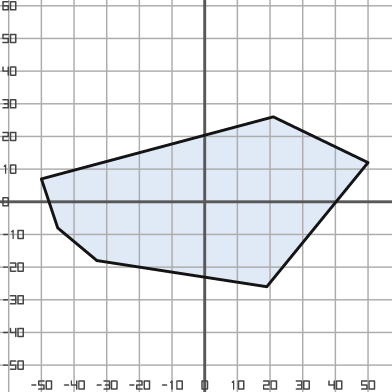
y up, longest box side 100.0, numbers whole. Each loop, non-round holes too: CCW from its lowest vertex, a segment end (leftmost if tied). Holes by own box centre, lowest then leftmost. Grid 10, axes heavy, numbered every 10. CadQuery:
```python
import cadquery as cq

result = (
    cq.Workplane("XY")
    .moveTo(19.0, -26.0)
    .lineTo(50.0, 12.0)
    .lineTo(21.0, 26.0)
    .lineTo(-50.0, 7.0)
    .lineTo(-45.0, -8.0)
    .lineTo(-33.0, -18.0)
    .close()
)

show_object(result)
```